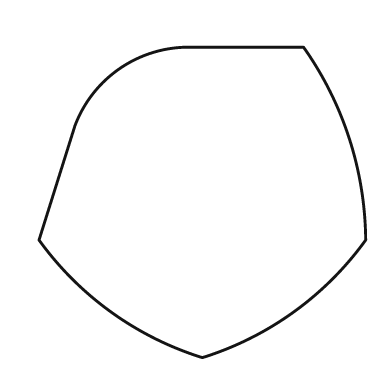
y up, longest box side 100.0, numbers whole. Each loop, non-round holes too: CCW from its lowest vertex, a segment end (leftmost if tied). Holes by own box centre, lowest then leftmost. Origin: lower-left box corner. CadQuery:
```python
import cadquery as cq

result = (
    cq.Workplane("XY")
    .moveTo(50.0, 0.0)
    .threePointArc((78.0, 14.0), (100.0, 36.0))
    .threePointArc((95.0, 67.0), (81.0, 95.0))
    .lineTo(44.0, 95.0)
    .threePointArc((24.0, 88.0), (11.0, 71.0))
    .lineTo(0.0, 36.0)
    .threePointArc((22.0, 14.0), (50.0, 0.0))
    .close()
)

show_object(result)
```